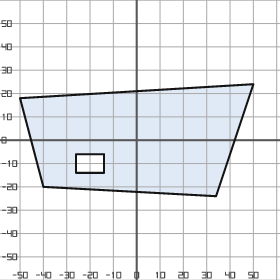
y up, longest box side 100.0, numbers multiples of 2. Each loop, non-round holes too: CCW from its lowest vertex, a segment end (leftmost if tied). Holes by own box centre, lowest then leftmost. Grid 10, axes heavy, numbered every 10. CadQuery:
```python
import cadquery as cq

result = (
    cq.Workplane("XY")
    .moveTo(34.0, -24.0)
    .lineTo(50.0, 24.0)
    .lineTo(-50.0, 18.0)
    .lineTo(-40.0, -20.0)
    .close()
    .moveTo(-26.0, -14.0)
    .lineTo(-14.0, -14.0)
    .lineTo(-14.0, -6.0)
    .lineTo(-26.0, -6.0)
    .close()
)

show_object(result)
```